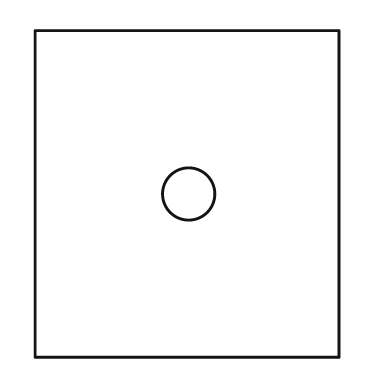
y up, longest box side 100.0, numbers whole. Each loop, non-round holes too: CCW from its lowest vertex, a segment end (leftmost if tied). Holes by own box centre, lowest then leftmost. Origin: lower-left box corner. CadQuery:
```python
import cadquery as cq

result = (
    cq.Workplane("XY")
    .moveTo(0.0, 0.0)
    .lineTo(93.0, 0.0)
    .lineTo(93.0, 100.0)
    .lineTo(0.0, 100.0)
    .close()
    .moveTo(47.0, 50.0)
    .circle(8.0)
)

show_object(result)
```